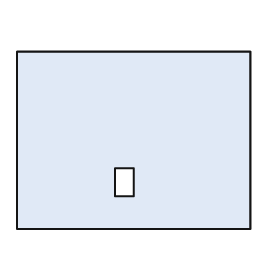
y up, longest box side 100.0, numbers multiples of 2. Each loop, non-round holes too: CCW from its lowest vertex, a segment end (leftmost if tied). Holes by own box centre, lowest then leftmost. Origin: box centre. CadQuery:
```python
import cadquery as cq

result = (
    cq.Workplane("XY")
    .moveTo(-50.0, -38.0)
    .lineTo(50.0, -38.0)
    .lineTo(50.0, 38.0)
    .lineTo(-50.0, 38.0)
    .close()
    .moveTo(-8.0, -24.0)
    .lineTo(0.0, -24.0)
    .lineTo(0.0, -12.0)
    .lineTo(-8.0, -12.0)
    .close()
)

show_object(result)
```